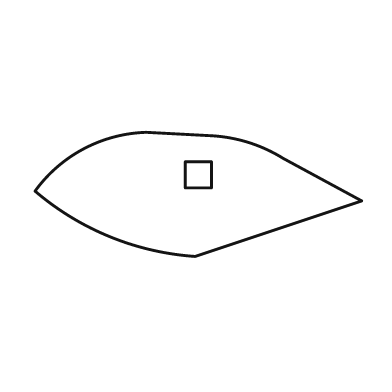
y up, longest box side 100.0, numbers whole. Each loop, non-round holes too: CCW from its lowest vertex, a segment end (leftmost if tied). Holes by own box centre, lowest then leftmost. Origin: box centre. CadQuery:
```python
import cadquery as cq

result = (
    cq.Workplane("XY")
    .moveTo(-1.0, -19.0)
    .lineTo(50.0, -2.0)
    .lineTo(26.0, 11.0)
    .threePointArc((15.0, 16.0), (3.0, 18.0))
    .lineTo(-16.0, 19.0)
    .threePointArc((-35.0, 14.0), (-50.0, 1.0))
    .threePointArc((-27.0, -13.0), (-1.0, -19.0))
    .close()
    .moveTo(-4.0, 2.0)
    .lineTo(4.0, 2.0)
    .lineTo(4.0, 10.0)
    .lineTo(-4.0, 10.0)
    .close()
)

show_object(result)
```